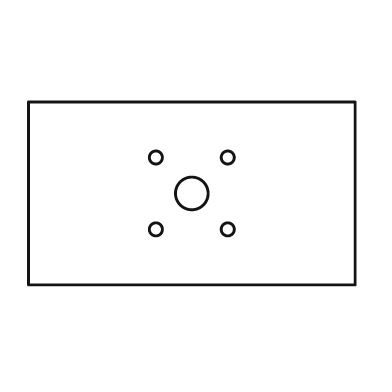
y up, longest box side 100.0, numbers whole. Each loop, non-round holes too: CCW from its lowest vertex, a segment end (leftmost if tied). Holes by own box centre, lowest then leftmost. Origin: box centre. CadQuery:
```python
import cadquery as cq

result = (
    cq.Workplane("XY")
    .moveTo(-50.0, -28.0)
    .lineTo(50.0, -28.0)
    .lineTo(50.0, 28.0)
    .lineTo(-50.0, 28.0)
    .close()
    .moveTo(-11.0, -11.0)
    .circle(2.0)
    .moveTo(11.0, -11.0)
    .circle(2.0)
    .moveTo(0.0, 0.0)
    .circle(5.0)
    .moveTo(-11.0, 11.0)
    .circle(2.0)
    .moveTo(11.0, 11.0)
    .circle(2.0)
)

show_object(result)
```